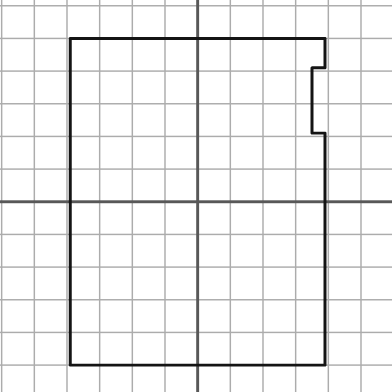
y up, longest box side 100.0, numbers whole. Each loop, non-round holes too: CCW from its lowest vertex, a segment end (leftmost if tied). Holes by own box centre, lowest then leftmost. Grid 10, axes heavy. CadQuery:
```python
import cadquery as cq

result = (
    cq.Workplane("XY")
    .moveTo(-39.0, -50.0)
    .lineTo(39.0, -50.0)
    .lineTo(39.0, 21.0)
    .lineTo(35.0, 21.0)
    .lineTo(35.0, 41.0)
    .lineTo(39.0, 41.0)
    .lineTo(39.0, 50.0)
    .lineTo(-39.0, 50.0)
    .close()
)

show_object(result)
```